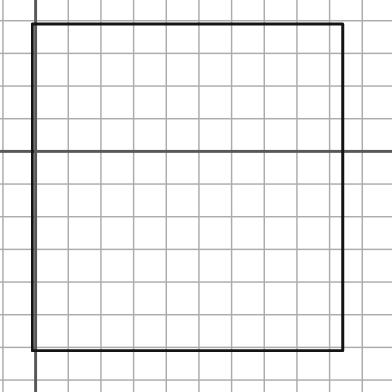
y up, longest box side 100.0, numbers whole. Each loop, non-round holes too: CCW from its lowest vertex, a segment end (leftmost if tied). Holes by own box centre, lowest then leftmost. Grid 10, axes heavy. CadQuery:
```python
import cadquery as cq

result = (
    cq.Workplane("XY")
    .moveTo(-1.0, -61.0)
    .lineTo(94.0, -61.0)
    .lineTo(94.0, 39.0)
    .lineTo(-1.0, 39.0)
    .close()
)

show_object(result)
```